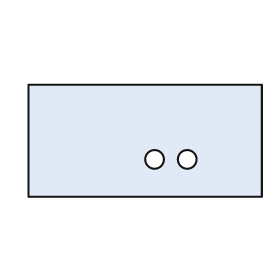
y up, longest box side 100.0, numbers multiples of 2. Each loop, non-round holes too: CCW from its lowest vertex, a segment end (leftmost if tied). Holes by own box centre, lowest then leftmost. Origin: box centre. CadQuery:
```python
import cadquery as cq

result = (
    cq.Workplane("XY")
    .moveTo(-50.0, -24.0)
    .lineTo(50.0, -24.0)
    .lineTo(50.0, 24.0)
    .lineTo(-50.0, 24.0)
    .close()
    .moveTo(4.0, -8.0)
    .circle(4.0)
    .moveTo(18.0, -8.0)
    .circle(4.0)
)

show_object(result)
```